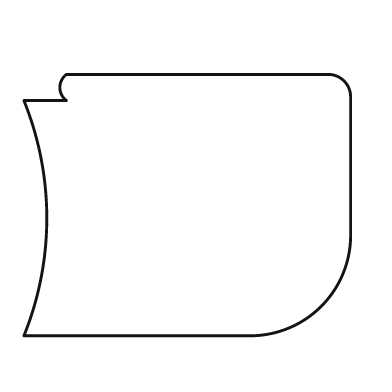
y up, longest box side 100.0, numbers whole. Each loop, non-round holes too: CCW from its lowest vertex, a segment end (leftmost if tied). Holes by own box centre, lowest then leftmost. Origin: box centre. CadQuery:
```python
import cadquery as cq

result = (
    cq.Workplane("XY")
    .moveTo(-50.0, -40.0)
    .lineTo(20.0, -40.0)
    .threePointArc((41.0, -31.0), (50.0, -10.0))
    .lineTo(50.0, 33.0)
    .threePointArc((48.0, 38.0), (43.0, 40.0))
    .lineTo(-37.0, 40.0)
    .threePointArc((-39.0, 36.0), (-37.0, 32.0))
    .lineTo(-50.0, 32.0)
    .threePointArc((-43.0, -4.0), (-50.0, -40.0))
    .close()
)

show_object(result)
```